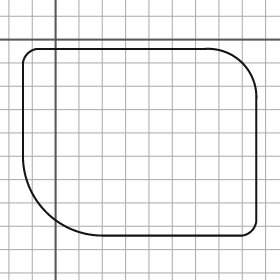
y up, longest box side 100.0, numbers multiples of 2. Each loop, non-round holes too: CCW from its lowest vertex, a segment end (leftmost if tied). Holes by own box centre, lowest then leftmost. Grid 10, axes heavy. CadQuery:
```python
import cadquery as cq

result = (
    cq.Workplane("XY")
    .moveTo(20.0, -84.0)
    .lineTo(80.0, -84.0)
    .threePointArc((84.0, -82.0), (86.0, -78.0))
    .lineTo(86.0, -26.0)
    .threePointArc((80.0, -10.0), (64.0, -4.0))
    .lineTo(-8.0, -4.0)
    .threePointArc((-12.0, -6.0), (-14.0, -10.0))
    .lineTo(-14.0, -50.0)
    .threePointArc((-4.0, -74.0), (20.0, -84.0))
    .close()
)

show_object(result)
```